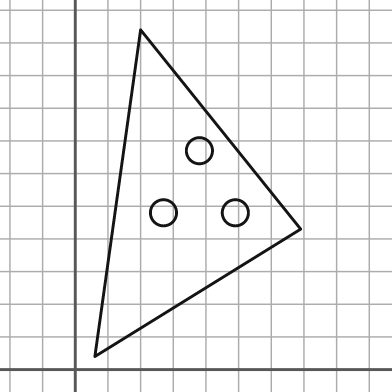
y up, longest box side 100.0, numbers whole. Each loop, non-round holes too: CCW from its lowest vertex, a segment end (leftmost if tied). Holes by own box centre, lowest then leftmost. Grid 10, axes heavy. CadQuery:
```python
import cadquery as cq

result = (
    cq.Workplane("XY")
    .moveTo(6.0, 4.0)
    .lineTo(69.0, 43.0)
    .lineTo(20.0, 104.0)
    .close()
    .moveTo(27.0, 48.0)
    .circle(4.0)
    .moveTo(49.0, 48.0)
    .circle(4.0)
    .moveTo(38.0, 67.0)
    .circle(4.0)
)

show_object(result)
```